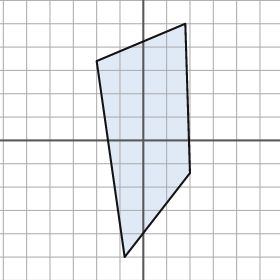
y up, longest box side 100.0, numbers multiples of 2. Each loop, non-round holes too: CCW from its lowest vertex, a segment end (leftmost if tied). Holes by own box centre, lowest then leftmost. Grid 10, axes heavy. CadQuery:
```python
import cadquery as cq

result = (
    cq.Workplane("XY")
    .moveTo(-8.0, -50.0)
    .lineTo(20.0, -14.0)
    .lineTo(18.0, 50.0)
    .lineTo(-20.0, 34.0)
    .close()
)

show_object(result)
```